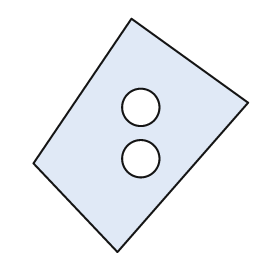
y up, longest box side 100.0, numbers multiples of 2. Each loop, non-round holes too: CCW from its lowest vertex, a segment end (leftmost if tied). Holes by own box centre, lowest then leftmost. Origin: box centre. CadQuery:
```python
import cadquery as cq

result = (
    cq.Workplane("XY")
    .moveTo(-10.0, -50.0)
    .lineTo(46.0, 14.0)
    .lineTo(-4.0, 50.0)
    .lineTo(-46.0, -12.0)
    .close()
    .moveTo(0.0, -10.0)
    .circle(8.0)
    .moveTo(0.0, 12.0)
    .circle(8.0)
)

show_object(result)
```